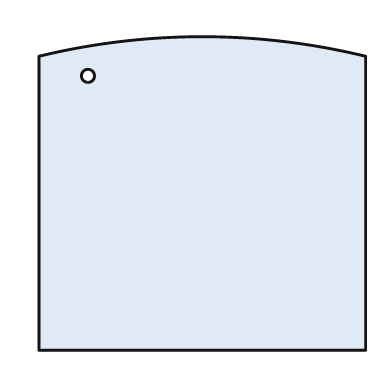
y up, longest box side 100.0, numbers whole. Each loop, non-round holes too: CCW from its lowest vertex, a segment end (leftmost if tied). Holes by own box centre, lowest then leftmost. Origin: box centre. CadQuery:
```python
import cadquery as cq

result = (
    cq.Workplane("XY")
    .moveTo(-50.0, -48.0)
    .lineTo(50.0, -48.0)
    .lineTo(50.0, 42.0)
    .threePointArc((0.0, 48.0), (-50.0, 42.0))
    .close()
    .moveTo(-35.0, 36.0)
    .circle(2.0)
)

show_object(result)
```